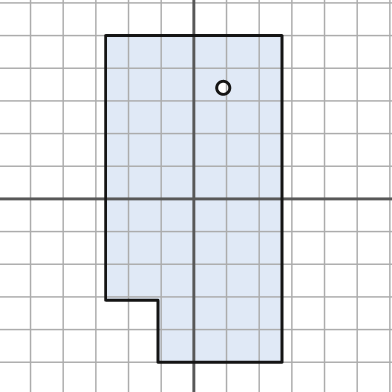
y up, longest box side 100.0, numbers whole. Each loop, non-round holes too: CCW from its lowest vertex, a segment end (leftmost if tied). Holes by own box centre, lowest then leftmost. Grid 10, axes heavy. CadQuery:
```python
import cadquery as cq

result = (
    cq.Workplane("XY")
    .moveTo(-11.0, -50.0)
    .lineTo(27.0, -50.0)
    .lineTo(27.0, 50.0)
    .lineTo(-27.0, 50.0)
    .lineTo(-27.0, -31.0)
    .lineTo(-11.0, -31.0)
    .close()
    .moveTo(9.0, 34.0)
    .circle(2.0)
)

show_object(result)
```